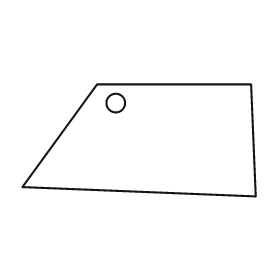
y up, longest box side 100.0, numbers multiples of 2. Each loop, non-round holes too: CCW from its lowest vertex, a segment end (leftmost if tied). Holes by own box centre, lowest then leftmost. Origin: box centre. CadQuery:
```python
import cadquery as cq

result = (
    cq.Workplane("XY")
    .moveTo(50.0, -24.0)
    .lineTo(48.0, 24.0)
    .lineTo(-18.0, 24.0)
    .lineTo(-50.0, -20.0)
    .close()
    .moveTo(-10.0, 16.0)
    .circle(4.0)
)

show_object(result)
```